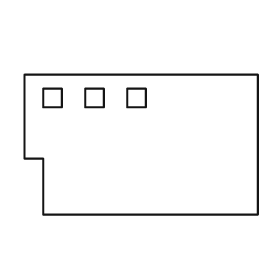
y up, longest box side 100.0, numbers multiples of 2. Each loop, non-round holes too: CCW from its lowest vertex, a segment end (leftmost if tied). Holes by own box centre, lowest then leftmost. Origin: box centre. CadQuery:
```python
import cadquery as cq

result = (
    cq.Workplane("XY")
    .moveTo(-42.0, -30.0)
    .lineTo(50.0, -30.0)
    .lineTo(50.0, 30.0)
    .lineTo(-50.0, 30.0)
    .lineTo(-50.0, -6.0)
    .lineTo(-42.0, -6.0)
    .close()
    .moveTo(-42.0, 16.0)
    .lineTo(-34.0, 16.0)
    .lineTo(-34.0, 24.0)
    .lineTo(-42.0, 24.0)
    .close()
    .moveTo(-24.0, 16.0)
    .lineTo(-16.0, 16.0)
    .lineTo(-16.0, 24.0)
    .lineTo(-24.0, 24.0)
    .close()
    .moveTo(-6.0, 16.0)
    .lineTo(2.0, 16.0)
    .lineTo(2.0, 24.0)
    .lineTo(-6.0, 24.0)
    .close()
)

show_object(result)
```